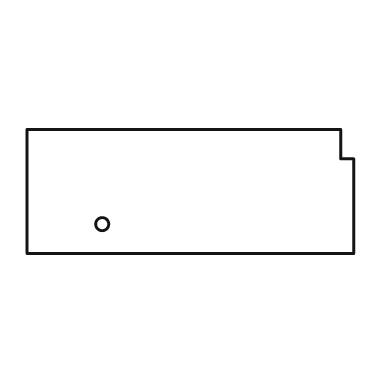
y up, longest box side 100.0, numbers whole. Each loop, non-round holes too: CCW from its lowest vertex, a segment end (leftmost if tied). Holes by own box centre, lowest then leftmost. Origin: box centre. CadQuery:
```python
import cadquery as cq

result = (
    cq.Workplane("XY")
    .moveTo(-50.0, -19.0)
    .lineTo(50.0, -19.0)
    .lineTo(50.0, 10.0)
    .lineTo(46.0, 10.0)
    .lineTo(46.0, 19.0)
    .lineTo(-50.0, 19.0)
    .close()
    .moveTo(-27.0, -10.0)
    .circle(2.0)
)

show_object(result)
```